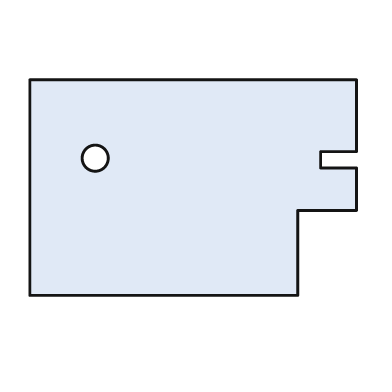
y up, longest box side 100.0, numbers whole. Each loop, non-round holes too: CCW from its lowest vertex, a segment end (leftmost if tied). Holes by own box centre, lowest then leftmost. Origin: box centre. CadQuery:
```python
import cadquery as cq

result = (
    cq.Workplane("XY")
    .moveTo(-50.0, -33.0)
    .lineTo(32.0, -33.0)
    .lineTo(32.0, -7.0)
    .lineTo(50.0, -7.0)
    .lineTo(50.0, 6.0)
    .lineTo(39.0, 6.0)
    .lineTo(39.0, 11.0)
    .lineTo(50.0, 11.0)
    .lineTo(50.0, 33.0)
    .lineTo(-50.0, 33.0)
    .close()
    .moveTo(-30.0, 9.0)
    .circle(4.0)
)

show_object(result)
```